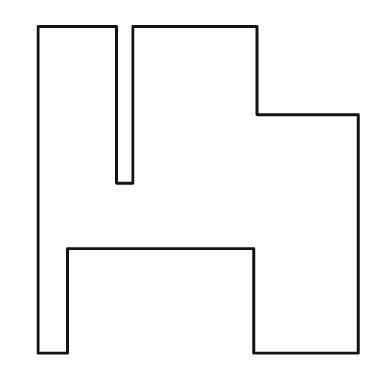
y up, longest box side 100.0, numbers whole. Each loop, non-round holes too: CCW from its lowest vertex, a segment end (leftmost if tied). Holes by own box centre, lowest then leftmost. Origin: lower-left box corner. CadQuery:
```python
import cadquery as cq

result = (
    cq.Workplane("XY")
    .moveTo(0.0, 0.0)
    .lineTo(9.0, 0.0)
    .lineTo(9.0, 32.0)
    .lineTo(66.0, 32.0)
    .lineTo(66.0, 0.0)
    .lineTo(98.0, 0.0)
    .lineTo(98.0, 73.0)
    .lineTo(67.0, 73.0)
    .lineTo(67.0, 100.0)
    .lineTo(29.0, 100.0)
    .lineTo(29.0, 52.0)
    .lineTo(24.0, 52.0)
    .lineTo(24.0, 100.0)
    .lineTo(0.0, 100.0)
    .close()
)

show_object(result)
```